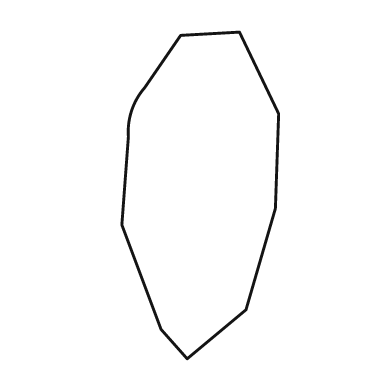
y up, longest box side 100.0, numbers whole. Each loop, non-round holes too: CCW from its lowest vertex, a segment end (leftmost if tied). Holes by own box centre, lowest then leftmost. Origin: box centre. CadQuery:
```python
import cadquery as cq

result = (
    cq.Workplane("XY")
    .moveTo(-4.0, -50.0)
    .lineTo(14.0, -35.0)
    .lineTo(23.0, -4.0)
    .lineTo(24.0, 25.0)
    .lineTo(12.0, 50.0)
    .lineTo(-6.0, 49.0)
    .lineTo(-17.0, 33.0)
    .threePointArc((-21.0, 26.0), (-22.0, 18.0))
    .lineTo(-24.0, -9.0)
    .lineTo(-12.0, -41.0)
    .close()
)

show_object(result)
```